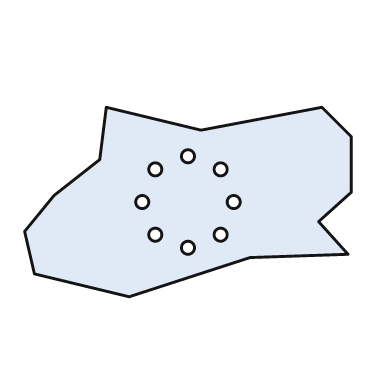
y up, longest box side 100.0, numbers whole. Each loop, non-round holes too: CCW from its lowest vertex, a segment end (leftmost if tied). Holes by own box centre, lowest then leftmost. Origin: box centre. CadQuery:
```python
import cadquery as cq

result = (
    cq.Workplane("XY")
    .moveTo(-18.0, -29.0)
    .lineTo(19.0, -17.0)
    .lineTo(49.0, -16.0)
    .lineTo(40.0, -6.0)
    .lineTo(50.0, 3.0)
    .lineTo(50.0, 20.0)
    .lineTo(41.0, 29.0)
    .lineTo(4.0, 22.0)
    .lineTo(-25.0, 29.0)
    .lineTo(-27.0, 13.0)
    .lineTo(-41.0, 2.0)
    .lineTo(-50.0, -9.0)
    .lineTo(-47.0, -22.0)
    .close()
    .moveTo(0.0, -14.0)
    .circle(2.0)
    .moveTo(-10.0, -10.0)
    .circle(2.0)
    .moveTo(10.0, -10.0)
    .circle(2.0)
    .moveTo(-14.0, 0.0)
    .circle(2.0)
    .moveTo(14.0, 0.0)
    .circle(2.0)
    .moveTo(-10.0, 10.0)
    .circle(2.0)
    .moveTo(10.0, 10.0)
    .circle(2.0)
    .moveTo(0.0, 14.0)
    .circle(2.0)
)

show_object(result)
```